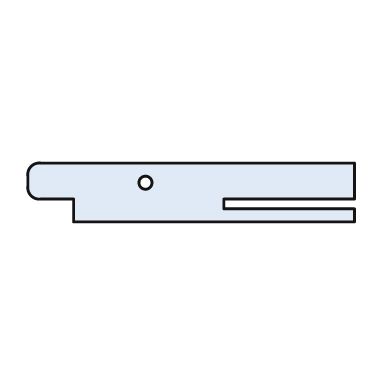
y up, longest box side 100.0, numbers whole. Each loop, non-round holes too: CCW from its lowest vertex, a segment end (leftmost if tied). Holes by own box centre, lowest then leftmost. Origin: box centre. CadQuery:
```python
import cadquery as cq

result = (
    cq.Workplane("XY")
    .moveTo(-36.0, -9.0)
    .lineTo(50.0, -9.0)
    .lineTo(50.0, -5.0)
    .lineTo(10.0, -5.0)
    .lineTo(10.0, -2.0)
    .lineTo(50.0, -2.0)
    .lineTo(50.0, 9.0)
    .lineTo(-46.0, 9.0)
    .threePointArc((-49.0, 8.0), (-50.0, 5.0))
    .lineTo(-50.0, 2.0)
    .threePointArc((-49.0, -1.0), (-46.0, -2.0))
    .lineTo(-36.0, -2.0)
    .close()
    .moveTo(-14.0, 3.0)
    .circle(2.0)
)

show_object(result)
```